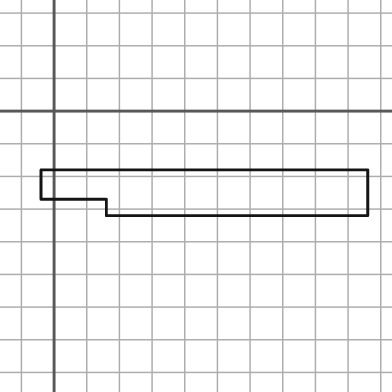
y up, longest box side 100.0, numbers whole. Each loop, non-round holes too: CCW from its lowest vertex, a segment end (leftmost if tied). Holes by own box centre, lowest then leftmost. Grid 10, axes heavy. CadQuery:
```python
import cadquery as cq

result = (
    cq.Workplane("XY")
    .moveTo(16.0, -32.0)
    .lineTo(96.0, -32.0)
    .lineTo(96.0, -18.0)
    .lineTo(-4.0, -18.0)
    .lineTo(-4.0, -27.0)
    .lineTo(16.0, -27.0)
    .close()
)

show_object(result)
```